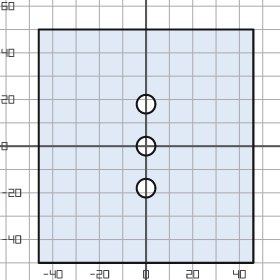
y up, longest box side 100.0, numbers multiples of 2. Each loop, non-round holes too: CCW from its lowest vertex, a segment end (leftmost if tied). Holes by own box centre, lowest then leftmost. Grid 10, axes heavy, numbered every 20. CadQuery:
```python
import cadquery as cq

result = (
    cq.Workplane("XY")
    .moveTo(-46.0, -50.0)
    .lineTo(46.0, -50.0)
    .lineTo(46.0, 50.0)
    .lineTo(-46.0, 50.0)
    .close()
    .moveTo(0.0, -18.0)
    .circle(4.0)
    .moveTo(0.0, 0.0)
    .circle(4.0)
    .moveTo(0.0, 18.0)
    .circle(4.0)
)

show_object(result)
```